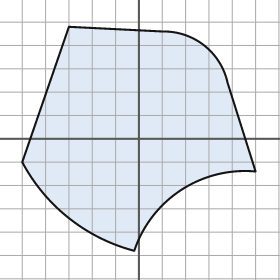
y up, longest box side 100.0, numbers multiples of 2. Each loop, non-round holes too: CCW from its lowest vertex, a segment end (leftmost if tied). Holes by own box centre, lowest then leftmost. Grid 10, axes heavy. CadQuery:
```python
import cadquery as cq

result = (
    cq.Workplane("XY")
    .moveTo(-2.0, -48.0)
    .threePointArc((18.0, -22.0), (50.0, -14.0))
    .lineTo(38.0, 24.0)
    .threePointArc((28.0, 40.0), (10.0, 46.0))
    .lineTo(-30.0, 48.0)
    .lineTo(-50.0, -10.0)
    .threePointArc((-30.0, -34.0), (-2.0, -48.0))
    .close()
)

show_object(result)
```